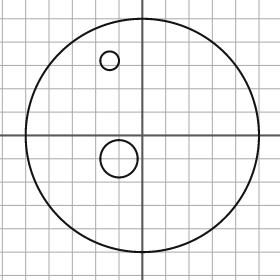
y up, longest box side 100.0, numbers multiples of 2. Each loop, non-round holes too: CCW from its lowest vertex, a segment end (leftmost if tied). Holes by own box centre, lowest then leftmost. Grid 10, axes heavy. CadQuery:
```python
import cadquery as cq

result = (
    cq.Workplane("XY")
    .moveTo(0.0, 0.0)
    .circle(50.0)
    .moveTo(-10.0, -10.0)
    .circle(8.0)
    .moveTo(-14.0, 32.0)
    .circle(4.0)
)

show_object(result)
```